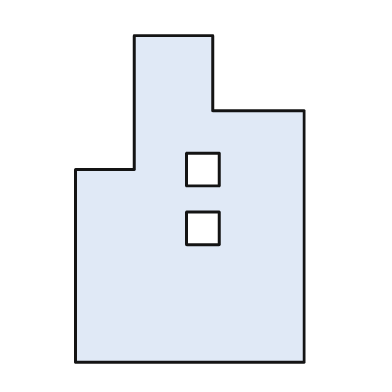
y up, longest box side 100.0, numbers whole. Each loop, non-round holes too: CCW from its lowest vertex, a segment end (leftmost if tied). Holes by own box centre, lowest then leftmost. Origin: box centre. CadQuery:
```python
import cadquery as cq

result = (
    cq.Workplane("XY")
    .moveTo(-35.0, -50.0)
    .lineTo(35.0, -50.0)
    .lineTo(35.0, 27.0)
    .lineTo(7.0, 27.0)
    .lineTo(7.0, 50.0)
    .lineTo(-17.0, 50.0)
    .lineTo(-17.0, 9.0)
    .lineTo(-35.0, 9.0)
    .close()
    .moveTo(-1.0, -14.0)
    .lineTo(9.0, -14.0)
    .lineTo(9.0, -4.0)
    .lineTo(-1.0, -4.0)
    .close()
    .moveTo(-1.0, 4.0)
    .lineTo(9.0, 4.0)
    .lineTo(9.0, 14.0)
    .lineTo(-1.0, 14.0)
    .close()
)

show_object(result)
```